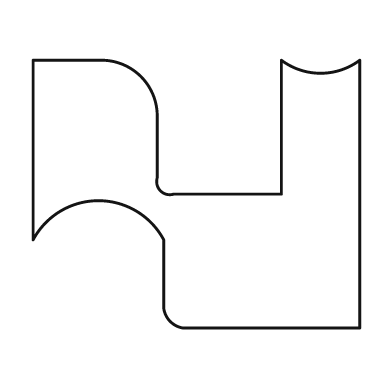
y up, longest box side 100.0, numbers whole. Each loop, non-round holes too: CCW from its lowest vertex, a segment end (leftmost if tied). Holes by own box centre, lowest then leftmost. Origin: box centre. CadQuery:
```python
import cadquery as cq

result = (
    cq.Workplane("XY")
    .moveTo(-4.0, -41.0)
    .lineTo(50.0, -41.0)
    .lineTo(50.0, 41.0)
    .threePointArc((38.0, 37.0), (26.0, 41.0))
    .lineTo(26.0, 0.0)
    .lineTo(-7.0, 0.0)
    .threePointArc((-11.0, 1.0), (-12.0, 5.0))
    .lineTo(-12.0, 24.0)
    .threePointArc((-17.0, 36.0), (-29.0, 41.0))
    .lineTo(-50.0, 41.0)
    .lineTo(-50.0, -14.0)
    .threePointArc((-30.0, -2.0), (-10.0, -14.0))
    .lineTo(-10.0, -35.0)
    .threePointArc((-8.0, -39.0), (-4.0, -41.0))
    .close()
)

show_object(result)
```